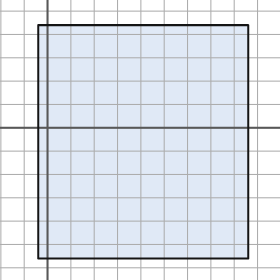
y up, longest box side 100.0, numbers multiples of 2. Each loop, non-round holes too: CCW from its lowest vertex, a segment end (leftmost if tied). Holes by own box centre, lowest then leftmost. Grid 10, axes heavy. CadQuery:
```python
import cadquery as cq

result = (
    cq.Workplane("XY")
    .moveTo(-4.0, -56.0)
    .lineTo(86.0, -56.0)
    .lineTo(86.0, 44.0)
    .lineTo(-4.0, 44.0)
    .close()
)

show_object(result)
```